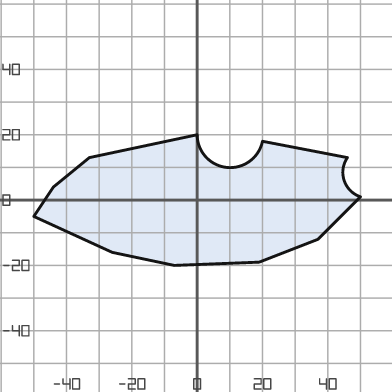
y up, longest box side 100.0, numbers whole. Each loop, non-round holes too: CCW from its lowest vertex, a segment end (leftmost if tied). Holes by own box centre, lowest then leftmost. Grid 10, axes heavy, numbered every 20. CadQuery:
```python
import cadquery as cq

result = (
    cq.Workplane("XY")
    .moveTo(-7.0, -20.0)
    .lineTo(19.0, -19.0)
    .lineTo(37.0, -12.0)
    .lineTo(50.0, 1.0)
    .threePointArc((45.0, 6.0), (46.0, 13.0))
    .lineTo(20.0, 18.0)
    .threePointArc((9.0, 10.0), (0.0, 20.0))
    .lineTo(-33.0, 13.0)
    .lineTo(-44.0, 4.0)
    .lineTo(-50.0, -5.0)
    .lineTo(-26.0, -16.0)
    .close()
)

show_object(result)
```